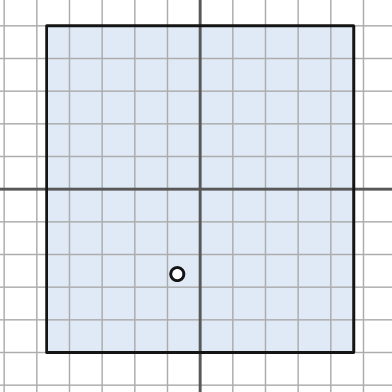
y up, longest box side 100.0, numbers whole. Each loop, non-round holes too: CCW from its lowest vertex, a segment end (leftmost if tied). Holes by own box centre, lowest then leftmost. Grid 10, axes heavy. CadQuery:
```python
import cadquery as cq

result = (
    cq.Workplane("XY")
    .moveTo(-47.0, -50.0)
    .lineTo(47.0, -50.0)
    .lineTo(47.0, 50.0)
    .lineTo(-47.0, 50.0)
    .close()
    .moveTo(-7.0, -26.0)
    .circle(2.0)
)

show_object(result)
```